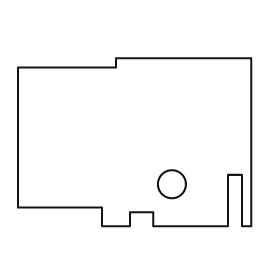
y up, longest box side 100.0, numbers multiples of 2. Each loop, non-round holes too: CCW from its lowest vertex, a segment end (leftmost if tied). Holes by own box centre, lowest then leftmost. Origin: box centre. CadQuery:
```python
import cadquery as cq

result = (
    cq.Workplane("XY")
    .moveTo(-14.0, -36.0)
    .lineTo(-2.0, -36.0)
    .lineTo(-2.0, -30.0)
    .lineTo(8.0, -30.0)
    .lineTo(8.0, -36.0)
    .lineTo(40.0, -36.0)
    .lineTo(40.0, -14.0)
    .lineTo(46.0, -14.0)
    .lineTo(46.0, -36.0)
    .lineTo(50.0, -36.0)
    .lineTo(50.0, 36.0)
    .lineTo(-8.0, 36.0)
    .lineTo(-8.0, 32.0)
    .lineTo(-50.0, 32.0)
    .lineTo(-50.0, -28.0)
    .lineTo(-14.0, -28.0)
    .close()
    .moveTo(16.0, -18.0)
    .circle(6.0)
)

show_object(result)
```